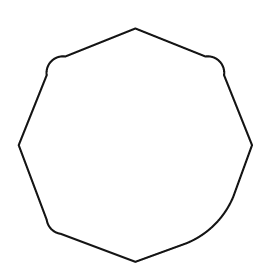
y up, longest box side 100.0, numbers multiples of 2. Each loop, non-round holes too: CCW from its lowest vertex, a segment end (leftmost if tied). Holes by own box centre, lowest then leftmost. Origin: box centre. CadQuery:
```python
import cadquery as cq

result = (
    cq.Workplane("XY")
    .moveTo(0.0, -50.0)
    .lineTo(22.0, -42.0)
    .threePointArc((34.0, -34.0), (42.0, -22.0))
    .lineTo(50.0, 0.0)
    .lineTo(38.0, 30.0)
    .threePointArc((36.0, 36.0), (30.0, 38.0))
    .lineTo(0.0, 50.0)
    .lineTo(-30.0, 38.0)
    .threePointArc((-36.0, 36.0), (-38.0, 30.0))
    .lineTo(-50.0, 0.0)
    .lineTo(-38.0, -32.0)
    .threePointArc((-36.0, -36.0), (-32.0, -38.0))
    .close()
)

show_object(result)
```